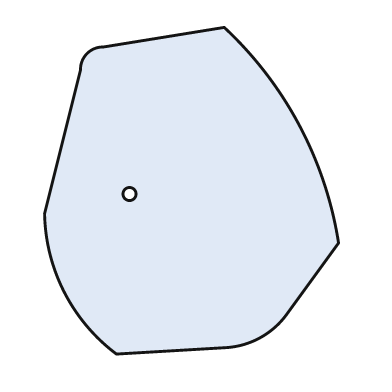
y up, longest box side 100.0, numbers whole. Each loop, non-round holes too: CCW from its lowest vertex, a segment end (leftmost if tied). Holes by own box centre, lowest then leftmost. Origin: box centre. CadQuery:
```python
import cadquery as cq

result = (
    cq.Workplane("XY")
    .moveTo(-23.0, -50.0)
    .lineTo(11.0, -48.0)
    .threePointArc((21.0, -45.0), (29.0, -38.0))
    .lineTo(45.0, -16.0)
    .threePointArc((33.0, 20.0), (10.0, 50.0))
    .lineTo(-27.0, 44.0)
    .threePointArc((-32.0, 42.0), (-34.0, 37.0))
    .lineTo(-45.0, -7.0)
    .threePointArc((-39.0, -31.0), (-23.0, -50.0))
    .close()
    .moveTo(-19.0, -1.0)
    .circle(2.0)
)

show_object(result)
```